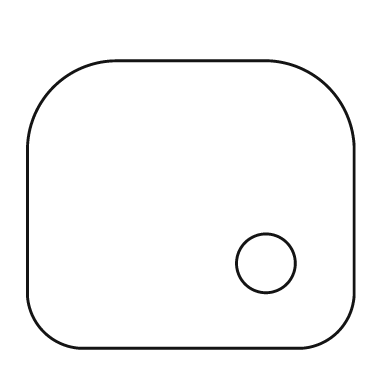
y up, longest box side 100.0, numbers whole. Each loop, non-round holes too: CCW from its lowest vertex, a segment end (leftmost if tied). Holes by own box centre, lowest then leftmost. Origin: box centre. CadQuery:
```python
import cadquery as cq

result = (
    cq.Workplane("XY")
    .moveTo(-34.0, -44.0)
    .lineTo(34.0, -44.0)
    .threePointArc((45.0, -39.0), (50.0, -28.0))
    .lineTo(50.0, 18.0)
    .threePointArc((42.0, 36.0), (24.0, 44.0))
    .lineTo(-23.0, 44.0)
    .threePointArc((-42.0, 36.0), (-50.0, 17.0))
    .lineTo(-50.0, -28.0)
    .threePointArc((-45.0, -39.0), (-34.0, -44.0))
    .close()
    .moveTo(23.0, -18.0)
    .circle(9.0)
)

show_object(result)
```